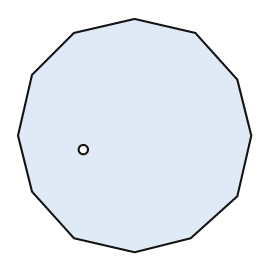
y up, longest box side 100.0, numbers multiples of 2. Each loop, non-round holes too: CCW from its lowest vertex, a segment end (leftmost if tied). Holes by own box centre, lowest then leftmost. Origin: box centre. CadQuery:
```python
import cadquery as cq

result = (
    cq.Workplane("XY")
    .moveTo(0.0, -50.0)
    .lineTo(24.0, -44.0)
    .lineTo(44.0, -26.0)
    .lineTo(50.0, 0.0)
    .lineTo(44.0, 24.0)
    .lineTo(26.0, 44.0)
    .lineTo(0.0, 50.0)
    .lineTo(-26.0, 44.0)
    .lineTo(-44.0, 26.0)
    .lineTo(-50.0, 0.0)
    .lineTo(-44.0, -24.0)
    .lineTo(-26.0, -44.0)
    .close()
    .moveTo(-22.0, -6.0)
    .circle(2.0)
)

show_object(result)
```